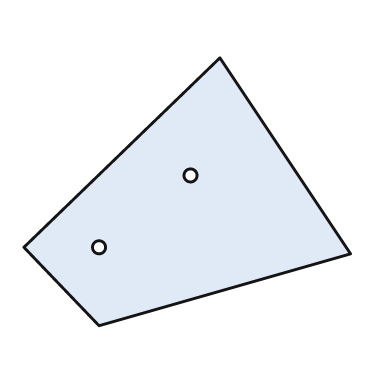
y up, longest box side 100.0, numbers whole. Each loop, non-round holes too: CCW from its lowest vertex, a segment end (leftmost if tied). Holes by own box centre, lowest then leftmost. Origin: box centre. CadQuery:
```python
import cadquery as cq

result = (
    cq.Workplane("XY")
    .moveTo(-27.0, -41.0)
    .lineTo(50.0, -19.0)
    .lineTo(10.0, 41.0)
    .lineTo(-50.0, -17.0)
    .close()
    .moveTo(-27.0, -17.0)
    .circle(2.0)
    .moveTo(1.0, 5.0)
    .circle(2.0)
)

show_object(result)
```